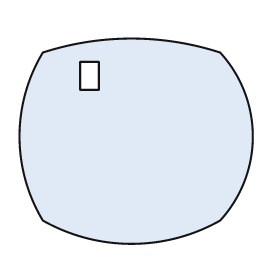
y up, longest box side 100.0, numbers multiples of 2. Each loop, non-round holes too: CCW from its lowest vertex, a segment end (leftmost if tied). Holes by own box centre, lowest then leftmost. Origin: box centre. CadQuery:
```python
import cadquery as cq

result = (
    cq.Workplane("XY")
    .moveTo(-40.0, -34.0)
    .threePointArc((-2.0, -44.0), (36.0, -34.0))
    .threePointArc((50.0, 2.0), (36.0, 38.0))
    .threePointArc((-2.0, 44.0), (-40.0, 38.0))
    .threePointArc((-50.0, 2.0), (-40.0, -34.0))
    .close()
    .moveTo(-24.0, 22.0)
    .lineTo(-16.0, 22.0)
    .lineTo(-16.0, 34.0)
    .lineTo(-24.0, 34.0)
    .close()
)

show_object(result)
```